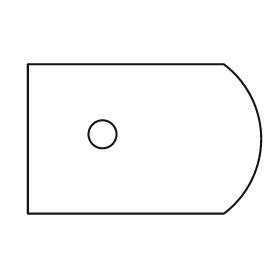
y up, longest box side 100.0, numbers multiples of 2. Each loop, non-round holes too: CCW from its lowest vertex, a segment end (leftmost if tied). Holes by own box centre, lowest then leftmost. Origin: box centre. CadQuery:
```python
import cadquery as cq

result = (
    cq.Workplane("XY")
    .moveTo(-50.0, -32.0)
    .lineTo(34.0, -32.0)
    .threePointArc((50.0, 0.0), (34.0, 32.0))
    .lineTo(-50.0, 32.0)
    .close()
    .moveTo(-18.0, 2.0)
    .circle(6.0)
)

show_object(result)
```